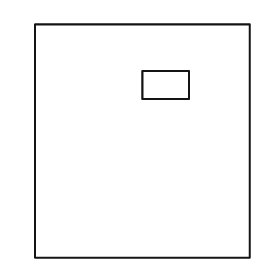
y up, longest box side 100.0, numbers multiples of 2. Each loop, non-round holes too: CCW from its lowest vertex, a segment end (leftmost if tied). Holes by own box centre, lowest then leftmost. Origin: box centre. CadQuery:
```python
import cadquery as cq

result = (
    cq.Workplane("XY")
    .moveTo(-46.0, -50.0)
    .lineTo(46.0, -50.0)
    .lineTo(46.0, 50.0)
    .lineTo(-46.0, 50.0)
    .close()
    .moveTo(0.0, 18.0)
    .lineTo(20.0, 18.0)
    .lineTo(20.0, 30.0)
    .lineTo(0.0, 30.0)
    .close()
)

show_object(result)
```